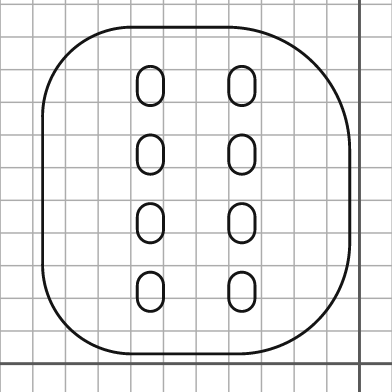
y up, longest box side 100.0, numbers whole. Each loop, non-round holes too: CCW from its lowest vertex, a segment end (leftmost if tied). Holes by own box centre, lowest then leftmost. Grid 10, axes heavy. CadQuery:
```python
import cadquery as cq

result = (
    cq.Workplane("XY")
    .moveTo(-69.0, 3.0)
    .lineTo(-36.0, 3.0)
    .threePointArc((-13.0, 13.0), (-3.0, 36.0))
    .lineTo(-3.0, 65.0)
    .threePointArc((-14.0, 92.0), (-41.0, 103.0))
    .lineTo(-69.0, 103.0)
    .threePointArc((-89.0, 95.0), (-97.0, 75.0))
    .lineTo(-97.0, 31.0)
    .threePointArc((-89.0, 11.0), (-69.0, 3.0))
    .close()
    .moveTo(-68.0, 20.0)
    .threePointArc((-64.0, 16.0), (-60.0, 20.0))
    .lineTo(-60.0, 24.0)
    .threePointArc((-64.0, 28.0), (-68.0, 24.0))
    .close()
    .moveTo(-40.0, 20.0)
    .threePointArc((-36.0, 16.0), (-32.0, 20.0))
    .lineTo(-32.0, 24.0)
    .threePointArc((-36.0, 28.0), (-40.0, 24.0))
    .close()
    .moveTo(-68.0, 41.0)
    .threePointArc((-64.0, 37.0), (-60.0, 41.0))
    .lineTo(-60.0, 45.0)
    .threePointArc((-64.0, 49.0), (-68.0, 45.0))
    .close()
    .moveTo(-40.0, 41.0)
    .threePointArc((-36.0, 37.0), (-32.0, 41.0))
    .lineTo(-32.0, 45.0)
    .threePointArc((-36.0, 49.0), (-40.0, 45.0))
    .close()
    .moveTo(-68.0, 62.0)
    .threePointArc((-64.0, 58.0), (-60.0, 62.0))
    .lineTo(-60.0, 66.0)
    .threePointArc((-64.0, 70.0), (-68.0, 66.0))
    .close()
    .moveTo(-40.0, 62.0)
    .threePointArc((-36.0, 58.0), (-32.0, 62.0))
    .lineTo(-32.0, 66.0)
    .threePointArc((-36.0, 70.0), (-40.0, 66.0))
    .close()
    .moveTo(-68.0, 83.0)
    .threePointArc((-64.0, 79.0), (-60.0, 83.0))
    .lineTo(-60.0, 87.0)
    .threePointArc((-64.0, 91.0), (-68.0, 87.0))
    .close()
    .moveTo(-40.0, 83.0)
    .threePointArc((-36.0, 79.0), (-32.0, 83.0))
    .lineTo(-32.0, 87.0)
    .threePointArc((-36.0, 91.0), (-40.0, 87.0))
    .close()
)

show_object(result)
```